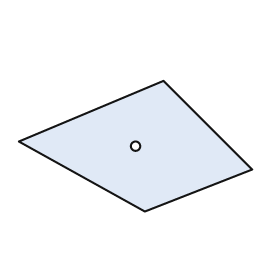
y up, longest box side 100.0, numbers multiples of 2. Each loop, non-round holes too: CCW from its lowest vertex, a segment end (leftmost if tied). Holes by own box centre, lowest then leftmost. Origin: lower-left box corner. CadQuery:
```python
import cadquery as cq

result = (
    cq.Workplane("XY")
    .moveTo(54.0, 0.0)
    .lineTo(100.0, 18.0)
    .lineTo(62.0, 56.0)
    .lineTo(0.0, 30.0)
    .close()
    .moveTo(50.0, 28.0)
    .circle(2.0)
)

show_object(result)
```